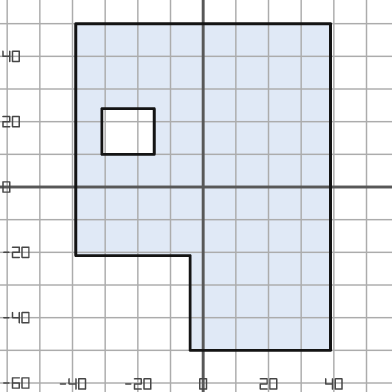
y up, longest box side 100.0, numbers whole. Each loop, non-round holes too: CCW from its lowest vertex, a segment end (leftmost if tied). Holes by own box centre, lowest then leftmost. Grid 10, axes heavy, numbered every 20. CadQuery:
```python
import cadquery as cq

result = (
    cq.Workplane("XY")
    .moveTo(-4.0, -50.0)
    .lineTo(39.0, -50.0)
    .lineTo(39.0, 50.0)
    .lineTo(-39.0, 50.0)
    .lineTo(-39.0, -21.0)
    .lineTo(-4.0, -21.0)
    .close()
    .moveTo(-31.0, 10.0)
    .lineTo(-15.0, 10.0)
    .lineTo(-15.0, 24.0)
    .lineTo(-31.0, 24.0)
    .close()
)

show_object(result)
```